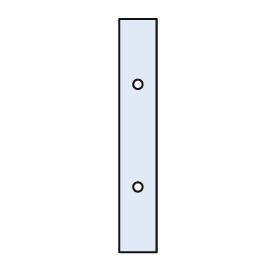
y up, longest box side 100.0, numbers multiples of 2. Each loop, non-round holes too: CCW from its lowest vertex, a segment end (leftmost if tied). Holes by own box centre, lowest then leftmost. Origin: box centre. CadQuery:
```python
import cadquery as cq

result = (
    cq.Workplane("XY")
    .moveTo(-8.0, -50.0)
    .lineTo(8.0, -50.0)
    .lineTo(8.0, 50.0)
    .lineTo(-8.0, 50.0)
    .close()
    .moveTo(0.0, -22.0)
    .circle(2.0)
    .moveTo(0.0, 22.0)
    .circle(2.0)
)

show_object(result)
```